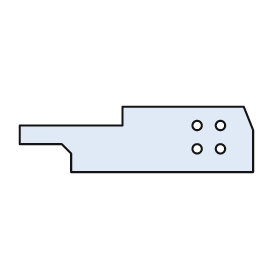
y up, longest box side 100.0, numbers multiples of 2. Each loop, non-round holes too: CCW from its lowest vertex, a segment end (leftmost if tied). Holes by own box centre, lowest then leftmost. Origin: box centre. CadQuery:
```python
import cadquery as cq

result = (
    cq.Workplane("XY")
    .moveTo(-28.0, -14.0)
    .lineTo(50.0, -14.0)
    .lineTo(50.0, 4.0)
    .lineTo(46.0, 14.0)
    .lineTo(-6.0, 14.0)
    .lineTo(-6.0, 6.0)
    .lineTo(-50.0, 6.0)
    .lineTo(-50.0, -2.0)
    .lineTo(-32.0, -2.0)
    .lineTo(-28.0, -6.0)
    .close()
    .moveTo(26.0, -4.0)
    .circle(2.0)
    .moveTo(36.0, -4.0)
    .circle(2.0)
    .moveTo(26.0, 6.0)
    .circle(2.0)
    .moveTo(36.0, 6.0)
    .circle(2.0)
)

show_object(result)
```